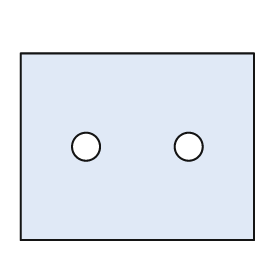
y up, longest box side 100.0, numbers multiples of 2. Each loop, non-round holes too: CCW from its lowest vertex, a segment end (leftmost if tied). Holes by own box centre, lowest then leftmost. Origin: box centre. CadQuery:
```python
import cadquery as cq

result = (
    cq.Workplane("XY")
    .moveTo(-50.0, -40.0)
    .lineTo(50.0, -40.0)
    .lineTo(50.0, 40.0)
    .lineTo(-50.0, 40.0)
    .close()
    .moveTo(-22.0, 0.0)
    .circle(6.0)
    .moveTo(22.0, 0.0)
    .circle(6.0)
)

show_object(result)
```